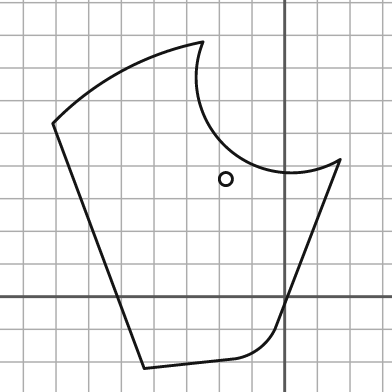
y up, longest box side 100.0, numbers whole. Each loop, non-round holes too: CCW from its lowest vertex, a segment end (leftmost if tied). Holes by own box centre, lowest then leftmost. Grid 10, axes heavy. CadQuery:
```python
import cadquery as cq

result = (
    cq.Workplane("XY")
    .moveTo(-43.0, -22.0)
    .lineTo(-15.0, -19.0)
    .threePointArc((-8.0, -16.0), (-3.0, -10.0))
    .lineTo(17.0, 42.0)
    .threePointArc((-17.0, 45.0), (-25.0, 78.0))
    .threePointArc((-50.0, 69.0), (-71.0, 53.0))
    .close()
    .moveTo(-18.0, 36.0)
    .circle(2.0)
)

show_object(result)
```